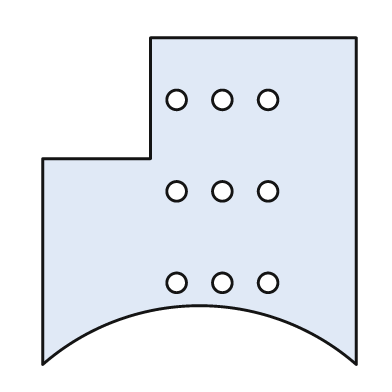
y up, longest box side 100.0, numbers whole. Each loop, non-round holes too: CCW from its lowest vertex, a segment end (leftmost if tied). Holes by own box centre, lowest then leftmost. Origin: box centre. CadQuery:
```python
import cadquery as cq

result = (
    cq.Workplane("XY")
    .moveTo(-48.0, -50.0)
    .threePointArc((0.0, -32.0), (48.0, -50.0))
    .lineTo(48.0, 50.0)
    .lineTo(-15.0, 50.0)
    .lineTo(-15.0, 13.0)
    .lineTo(-48.0, 13.0)
    .close()
    .moveTo(-7.0, -25.0)
    .circle(3.0)
    .moveTo(7.0, -25.0)
    .circle(3.0)
    .moveTo(21.0, -25.0)
    .circle(3.0)
    .moveTo(-7.0, 3.0)
    .circle(3.0)
    .moveTo(7.0, 3.0)
    .circle(3.0)
    .moveTo(21.0, 3.0)
    .circle(3.0)
    .moveTo(-7.0, 31.0)
    .circle(3.0)
    .moveTo(7.0, 31.0)
    .circle(3.0)
    .moveTo(21.0, 31.0)
    .circle(3.0)
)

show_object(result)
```